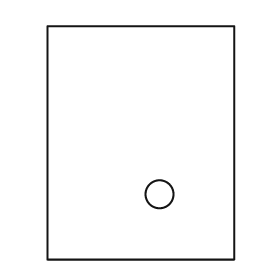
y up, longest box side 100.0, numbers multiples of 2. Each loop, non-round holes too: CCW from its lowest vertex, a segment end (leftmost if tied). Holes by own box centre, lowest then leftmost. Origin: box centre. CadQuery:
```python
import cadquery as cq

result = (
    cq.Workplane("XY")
    .moveTo(-40.0, -50.0)
    .lineTo(40.0, -50.0)
    .lineTo(40.0, 50.0)
    .lineTo(-40.0, 50.0)
    .close()
    .moveTo(8.0, -22.0)
    .circle(6.0)
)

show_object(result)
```